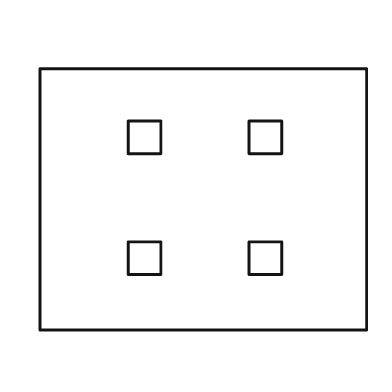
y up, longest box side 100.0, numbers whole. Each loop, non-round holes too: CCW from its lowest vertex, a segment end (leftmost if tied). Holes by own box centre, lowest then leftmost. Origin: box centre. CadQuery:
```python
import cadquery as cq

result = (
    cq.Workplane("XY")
    .moveTo(-50.0, -40.0)
    .lineTo(50.0, -40.0)
    .lineTo(50.0, 40.0)
    .lineTo(-50.0, 40.0)
    .close()
    .moveTo(-23.0, -23.0)
    .lineTo(-13.0, -23.0)
    .lineTo(-13.0, -13.0)
    .lineTo(-23.0, -13.0)
    .close()
    .moveTo(14.0, -23.0)
    .lineTo(24.0, -23.0)
    .lineTo(24.0, -13.0)
    .lineTo(14.0, -13.0)
    .close()
    .moveTo(-23.0, 14.0)
    .lineTo(-13.0, 14.0)
    .lineTo(-13.0, 24.0)
    .lineTo(-23.0, 24.0)
    .close()
    .moveTo(14.0, 14.0)
    .lineTo(24.0, 14.0)
    .lineTo(24.0, 24.0)
    .lineTo(14.0, 24.0)
    .close()
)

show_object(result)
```